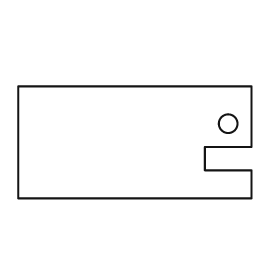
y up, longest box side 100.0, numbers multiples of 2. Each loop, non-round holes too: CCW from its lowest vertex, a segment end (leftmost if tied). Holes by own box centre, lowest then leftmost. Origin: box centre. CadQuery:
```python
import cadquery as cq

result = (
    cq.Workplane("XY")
    .moveTo(-50.0, -24.0)
    .lineTo(50.0, -24.0)
    .lineTo(50.0, -12.0)
    .lineTo(30.0, -12.0)
    .lineTo(30.0, -2.0)
    .lineTo(50.0, -2.0)
    .lineTo(50.0, 24.0)
    .lineTo(-50.0, 24.0)
    .close()
    .moveTo(40.0, 8.0)
    .circle(4.0)
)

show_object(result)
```